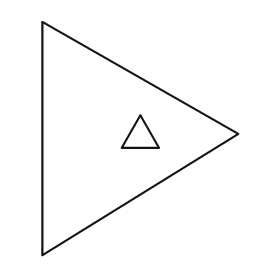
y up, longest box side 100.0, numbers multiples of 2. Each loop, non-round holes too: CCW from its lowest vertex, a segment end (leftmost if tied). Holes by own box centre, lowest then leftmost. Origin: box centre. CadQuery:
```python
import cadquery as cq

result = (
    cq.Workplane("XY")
    .moveTo(-42.0, -50.0)
    .lineTo(42.0, 2.0)
    .lineTo(-42.0, 50.0)
    .close()
    .moveTo(-8.0, -4.0)
    .lineTo(8.0, -4.0)
    .lineTo(0.0, 10.0)
    .close()
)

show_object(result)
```